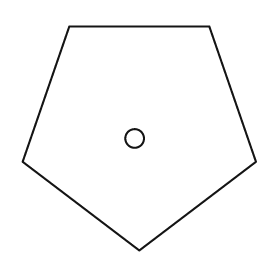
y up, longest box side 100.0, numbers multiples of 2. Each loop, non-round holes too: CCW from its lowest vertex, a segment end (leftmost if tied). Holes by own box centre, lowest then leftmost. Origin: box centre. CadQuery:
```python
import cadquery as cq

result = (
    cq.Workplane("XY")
    .moveTo(0.0, -48.0)
    .lineTo(50.0, -10.0)
    .lineTo(30.0, 48.0)
    .lineTo(-30.0, 48.0)
    .lineTo(-50.0, -10.0)
    .close()
    .moveTo(-2.0, 0.0)
    .circle(4.0)
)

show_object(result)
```